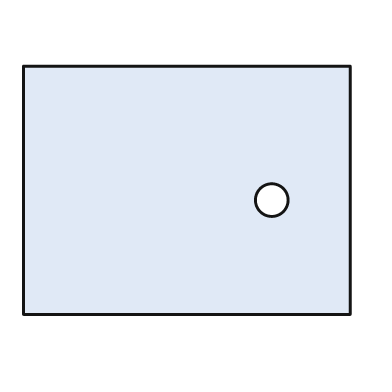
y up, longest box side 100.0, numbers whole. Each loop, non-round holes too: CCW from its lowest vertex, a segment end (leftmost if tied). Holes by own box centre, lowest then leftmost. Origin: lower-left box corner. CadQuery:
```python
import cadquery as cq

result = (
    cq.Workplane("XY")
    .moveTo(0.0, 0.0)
    .lineTo(100.0, 0.0)
    .lineTo(100.0, 76.0)
    .lineTo(0.0, 76.0)
    .close()
    .moveTo(76.0, 35.0)
    .circle(5.0)
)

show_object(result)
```